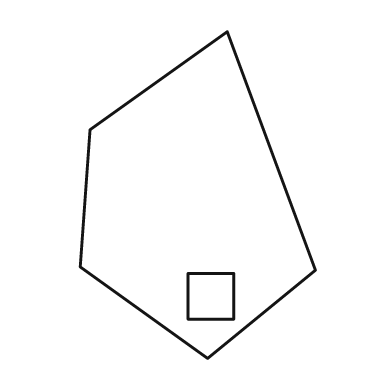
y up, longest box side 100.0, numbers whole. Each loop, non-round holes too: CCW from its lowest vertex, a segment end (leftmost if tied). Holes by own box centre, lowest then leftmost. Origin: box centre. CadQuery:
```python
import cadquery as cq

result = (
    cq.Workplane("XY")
    .moveTo(3.0, -50.0)
    .lineTo(36.0, -23.0)
    .lineTo(9.0, 50.0)
    .lineTo(-33.0, 20.0)
    .lineTo(-36.0, -22.0)
    .close()
    .moveTo(-3.0, -38.0)
    .lineTo(11.0, -38.0)
    .lineTo(11.0, -24.0)
    .lineTo(-3.0, -24.0)
    .close()
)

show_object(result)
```